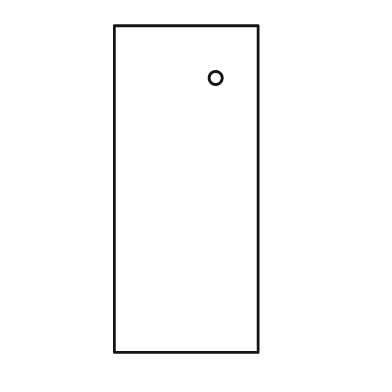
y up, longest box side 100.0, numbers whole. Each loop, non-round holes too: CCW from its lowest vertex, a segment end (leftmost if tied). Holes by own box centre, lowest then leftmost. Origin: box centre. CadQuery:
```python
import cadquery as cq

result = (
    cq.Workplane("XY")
    .moveTo(-22.0, -50.0)
    .lineTo(22.0, -50.0)
    .lineTo(22.0, 50.0)
    .lineTo(-22.0, 50.0)
    .close()
    .moveTo(9.0, 34.0)
    .circle(2.0)
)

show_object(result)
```